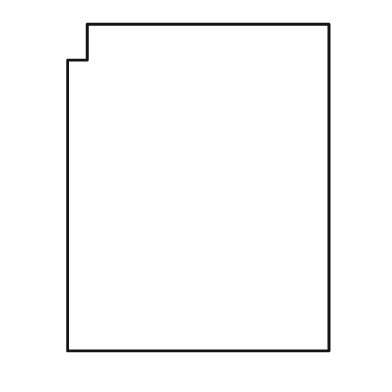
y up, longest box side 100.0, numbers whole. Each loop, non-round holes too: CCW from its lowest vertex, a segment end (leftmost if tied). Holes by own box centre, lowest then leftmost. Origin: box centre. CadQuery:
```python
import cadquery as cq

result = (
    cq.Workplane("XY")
    .moveTo(-40.0, -50.0)
    .lineTo(40.0, -50.0)
    .lineTo(40.0, 50.0)
    .lineTo(-34.0, 50.0)
    .lineTo(-34.0, 39.0)
    .lineTo(-40.0, 39.0)
    .close()
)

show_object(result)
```